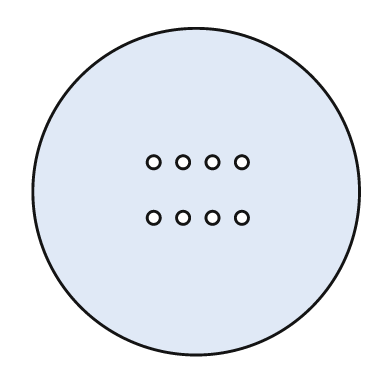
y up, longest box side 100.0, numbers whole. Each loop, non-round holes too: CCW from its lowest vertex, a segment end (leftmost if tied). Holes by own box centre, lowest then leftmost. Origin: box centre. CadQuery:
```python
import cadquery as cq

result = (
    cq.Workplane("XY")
    .moveTo(0.0, 0.0)
    .circle(50.0)
    .moveTo(-13.0, -8.0)
    .circle(2.0)
    .moveTo(-4.0, -8.0)
    .circle(2.0)
    .moveTo(5.0, -8.0)
    .circle(2.0)
    .moveTo(14.0, -8.0)
    .circle(2.0)
    .moveTo(-13.0, 9.0)
    .circle(2.0)
    .moveTo(-4.0, 9.0)
    .circle(2.0)
    .moveTo(5.0, 9.0)
    .circle(2.0)
    .moveTo(14.0, 9.0)
    .circle(2.0)
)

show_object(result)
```